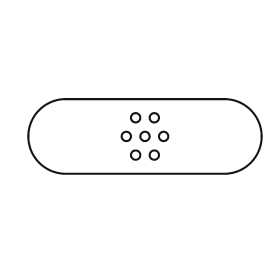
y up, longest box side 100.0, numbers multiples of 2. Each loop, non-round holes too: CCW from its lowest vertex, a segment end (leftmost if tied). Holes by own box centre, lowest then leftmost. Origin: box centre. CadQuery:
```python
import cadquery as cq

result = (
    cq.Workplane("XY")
    .moveTo(-34.0, -16.0)
    .lineTo(34.0, -16.0)
    .threePointArc((50.0, 0.0), (34.0, 16.0))
    .lineTo(-34.0, 16.0)
    .threePointArc((-50.0, 0.0), (-34.0, -16.0))
    .close()
    .moveTo(-4.0, -8.0)
    .circle(2.0)
    .moveTo(4.0, -8.0)
    .circle(2.0)
    .moveTo(-8.0, 0.0)
    .circle(2.0)
    .moveTo(0.0, 0.0)
    .circle(2.0)
    .moveTo(8.0, 0.0)
    .circle(2.0)
    .moveTo(-4.0, 8.0)
    .circle(2.0)
    .moveTo(4.0, 8.0)
    .circle(2.0)
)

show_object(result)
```